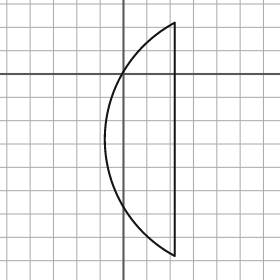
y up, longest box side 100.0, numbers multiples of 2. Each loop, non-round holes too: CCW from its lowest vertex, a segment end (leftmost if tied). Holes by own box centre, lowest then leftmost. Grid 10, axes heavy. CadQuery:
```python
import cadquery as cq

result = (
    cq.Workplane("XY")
    .moveTo(22.0, -78.0)
    .lineTo(22.0, 22.0)
    .threePointArc((-8.0, -28.0), (22.0, -78.0))
    .close()
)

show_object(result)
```